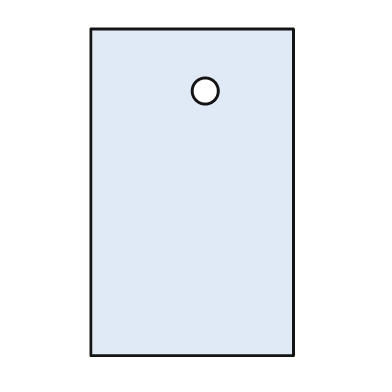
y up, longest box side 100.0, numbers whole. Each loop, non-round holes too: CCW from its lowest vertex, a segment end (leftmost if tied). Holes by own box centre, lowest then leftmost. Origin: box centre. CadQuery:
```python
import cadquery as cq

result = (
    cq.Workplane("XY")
    .moveTo(-31.0, -50.0)
    .lineTo(31.0, -50.0)
    .lineTo(31.0, 50.0)
    .lineTo(-31.0, 50.0)
    .close()
    .moveTo(4.0, 31.0)
    .circle(4.0)
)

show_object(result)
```